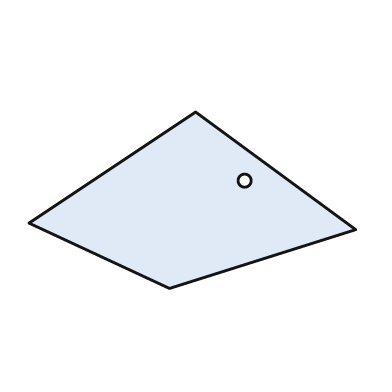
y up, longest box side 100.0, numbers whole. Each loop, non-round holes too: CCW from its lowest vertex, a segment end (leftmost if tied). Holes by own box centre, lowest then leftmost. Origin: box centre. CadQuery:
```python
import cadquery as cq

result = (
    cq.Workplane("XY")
    .moveTo(-7.0, -27.0)
    .lineTo(50.0, -9.0)
    .lineTo(1.0, 27.0)
    .lineTo(-50.0, -7.0)
    .close()
    .moveTo(16.0, 6.0)
    .circle(2.0)
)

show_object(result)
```